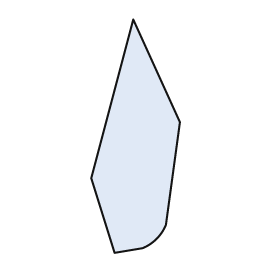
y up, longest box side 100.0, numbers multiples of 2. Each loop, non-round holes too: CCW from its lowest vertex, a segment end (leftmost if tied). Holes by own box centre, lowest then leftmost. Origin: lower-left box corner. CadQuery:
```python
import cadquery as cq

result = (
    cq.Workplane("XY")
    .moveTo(10.0, 0.0)
    .lineTo(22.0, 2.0)
    .threePointArc((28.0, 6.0), (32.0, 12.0))
    .lineTo(38.0, 56.0)
    .lineTo(18.0, 100.0)
    .lineTo(0.0, 32.0)
    .close()
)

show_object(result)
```